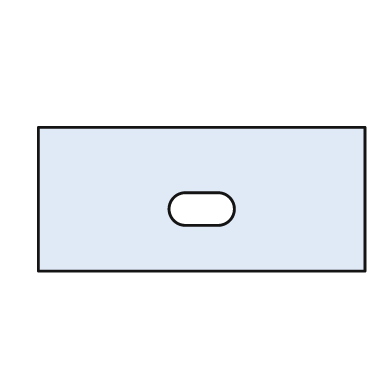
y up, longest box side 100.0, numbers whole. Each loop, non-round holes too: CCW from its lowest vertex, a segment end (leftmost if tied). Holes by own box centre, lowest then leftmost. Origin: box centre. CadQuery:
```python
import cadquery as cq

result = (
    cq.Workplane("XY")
    .moveTo(-50.0, -22.0)
    .lineTo(50.0, -22.0)
    .lineTo(50.0, 22.0)
    .lineTo(-50.0, 22.0)
    .close()
    .moveTo(-5.0, -8.0)
    .lineTo(5.0, -8.0)
    .threePointArc((10.0, -3.0), (5.0, 2.0))
    .lineTo(-5.0, 2.0)
    .threePointArc((-10.0, -3.0), (-5.0, -8.0))
    .close()
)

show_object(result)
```